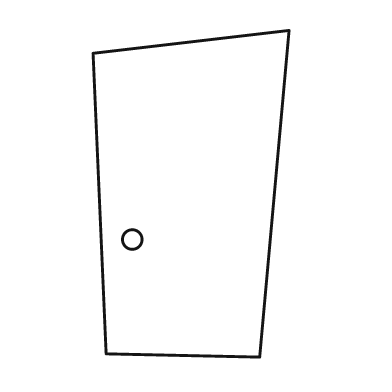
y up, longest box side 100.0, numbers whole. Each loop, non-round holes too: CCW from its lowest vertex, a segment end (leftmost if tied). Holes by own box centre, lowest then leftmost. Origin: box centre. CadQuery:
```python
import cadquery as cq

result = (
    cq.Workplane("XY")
    .moveTo(21.0, -50.0)
    .lineTo(30.0, 50.0)
    .lineTo(-30.0, 43.0)
    .lineTo(-26.0, -49.0)
    .close()
    .moveTo(-18.0, -14.0)
    .circle(3.0)
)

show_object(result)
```